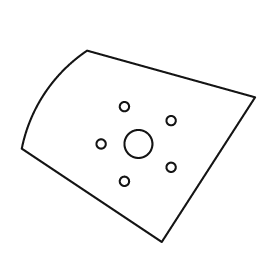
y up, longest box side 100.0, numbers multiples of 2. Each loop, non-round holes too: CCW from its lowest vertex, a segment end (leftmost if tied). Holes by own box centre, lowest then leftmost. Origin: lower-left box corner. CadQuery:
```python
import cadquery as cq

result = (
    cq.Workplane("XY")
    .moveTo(60.0, 0.0)
    .lineTo(100.0, 62.0)
    .lineTo(28.0, 82.0)
    .threePointArc((10.0, 64.0), (0.0, 40.0))
    .close()
    .moveTo(44.0, 26.0)
    .circle(2.0)
    .moveTo(64.0, 32.0)
    .circle(2.0)
    .moveTo(34.0, 42.0)
    .circle(2.0)
    .moveTo(50.0, 42.0)
    .circle(6.0)
    .moveTo(64.0, 52.0)
    .circle(2.0)
    .moveTo(44.0, 58.0)
    .circle(2.0)
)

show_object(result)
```